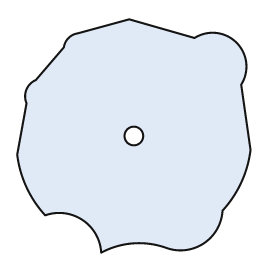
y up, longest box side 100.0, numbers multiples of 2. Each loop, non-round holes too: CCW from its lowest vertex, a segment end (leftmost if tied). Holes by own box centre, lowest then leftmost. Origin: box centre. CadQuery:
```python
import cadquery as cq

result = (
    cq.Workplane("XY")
    .moveTo(-14.0, -50.0)
    .threePointArc((0.0, -46.0), (14.0, -48.0))
    .threePointArc((30.0, -46.0), (38.0, -32.0))
    .threePointArc((46.0, -20.0), (50.0, -6.0))
    .lineTo(46.0, 22.0)
    .threePointArc((44.0, 40.0), (26.0, 42.0))
    .lineTo(-2.0, 50.0)
    .lineTo(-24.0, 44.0)
    .threePointArc((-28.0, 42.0), (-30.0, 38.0))
    .lineTo(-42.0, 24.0)
    .threePointArc((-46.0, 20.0), (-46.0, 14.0))
    .lineTo(-50.0, -8.0)
    .threePointArc((-46.0, -22.0), (-38.0, -34.0))
    .threePointArc((-22.0, -36.0), (-14.0, -50.0))
    .close()
    .moveTo(0.0, 0.0)
    .circle(4.0)
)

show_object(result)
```